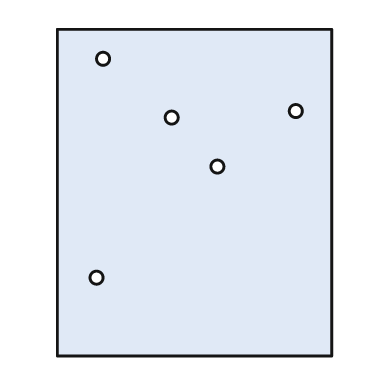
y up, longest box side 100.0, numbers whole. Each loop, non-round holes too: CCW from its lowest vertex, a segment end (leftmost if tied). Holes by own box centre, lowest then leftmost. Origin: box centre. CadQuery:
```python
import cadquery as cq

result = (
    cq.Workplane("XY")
    .moveTo(-42.0, -50.0)
    .lineTo(42.0, -50.0)
    .lineTo(42.0, 50.0)
    .lineTo(-42.0, 50.0)
    .close()
    .moveTo(-30.0, -26.0)
    .circle(2.0)
    .moveTo(7.0, 8.0)
    .circle(2.0)
    .moveTo(-7.0, 23.0)
    .circle(2.0)
    .moveTo(31.0, 25.0)
    .circle(2.0)
    .moveTo(-28.0, 41.0)
    .circle(2.0)
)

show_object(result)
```